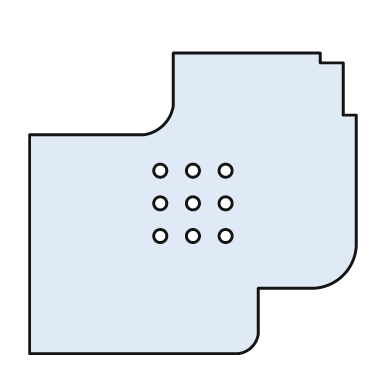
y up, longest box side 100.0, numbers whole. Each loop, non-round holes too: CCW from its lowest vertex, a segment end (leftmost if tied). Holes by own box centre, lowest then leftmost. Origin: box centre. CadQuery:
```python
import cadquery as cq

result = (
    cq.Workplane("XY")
    .moveTo(-50.0, -46.0)
    .lineTo(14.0, -46.0)
    .threePointArc((18.0, -44.0), (20.0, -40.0))
    .lineTo(20.0, -26.0)
    .lineTo(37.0, -26.0)
    .threePointArc((46.0, -22.0), (50.0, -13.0))
    .lineTo(50.0, 27.0)
    .lineTo(46.0, 27.0)
    .lineTo(46.0, 43.0)
    .lineTo(39.0, 43.0)
    .lineTo(39.0, 46.0)
    .lineTo(-6.0, 46.0)
    .lineTo(-6.0, 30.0)
    .threePointArc((-9.0, 24.0), (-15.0, 21.0))
    .lineTo(-50.0, 21.0)
    .close()
    .moveTo(-10.0, -10.0)
    .circle(2.0)
    .moveTo(0.0, -10.0)
    .circle(2.0)
    .moveTo(10.0, -10.0)
    .circle(2.0)
    .moveTo(-10.0, 0.0)
    .circle(2.0)
    .moveTo(0.0, 0.0)
    .circle(2.0)
    .moveTo(10.0, 0.0)
    .circle(2.0)
    .moveTo(-10.0, 10.0)
    .circle(2.0)
    .moveTo(0.0, 10.0)
    .circle(2.0)
    .moveTo(10.0, 10.0)
    .circle(2.0)
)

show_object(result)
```